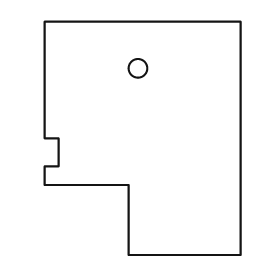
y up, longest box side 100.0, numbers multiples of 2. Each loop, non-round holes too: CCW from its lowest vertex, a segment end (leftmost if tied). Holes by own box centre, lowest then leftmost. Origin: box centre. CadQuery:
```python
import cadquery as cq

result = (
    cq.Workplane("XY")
    .moveTo(-6.0, -50.0)
    .lineTo(42.0, -50.0)
    .lineTo(42.0, 50.0)
    .lineTo(-42.0, 50.0)
    .lineTo(-42.0, 0.0)
    .lineTo(-36.0, 0.0)
    .lineTo(-36.0, -12.0)
    .lineTo(-42.0, -12.0)
    .lineTo(-42.0, -20.0)
    .lineTo(-6.0, -20.0)
    .close()
    .moveTo(-2.0, 30.0)
    .circle(4.0)
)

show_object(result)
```